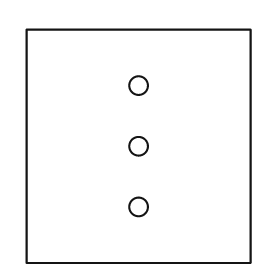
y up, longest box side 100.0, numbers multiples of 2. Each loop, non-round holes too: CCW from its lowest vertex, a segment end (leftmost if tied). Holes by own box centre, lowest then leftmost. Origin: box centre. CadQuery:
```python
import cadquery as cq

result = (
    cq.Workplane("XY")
    .moveTo(-48.0, -50.0)
    .lineTo(48.0, -50.0)
    .lineTo(48.0, 50.0)
    .lineTo(-48.0, 50.0)
    .close()
    .moveTo(0.0, -26.0)
    .circle(4.0)
    .moveTo(0.0, 0.0)
    .circle(4.0)
    .moveTo(0.0, 26.0)
    .circle(4.0)
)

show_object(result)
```